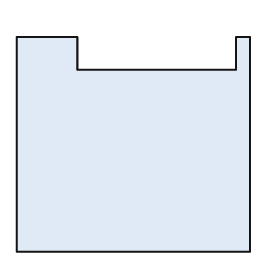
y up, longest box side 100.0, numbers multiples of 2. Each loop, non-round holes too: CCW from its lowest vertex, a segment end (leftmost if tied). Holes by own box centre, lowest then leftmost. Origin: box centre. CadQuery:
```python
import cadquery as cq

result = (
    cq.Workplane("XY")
    .moveTo(-50.0, -46.0)
    .lineTo(50.0, -46.0)
    .lineTo(50.0, 46.0)
    .lineTo(44.0, 46.0)
    .lineTo(44.0, 32.0)
    .lineTo(-24.0, 32.0)
    .lineTo(-24.0, 46.0)
    .lineTo(-50.0, 46.0)
    .close()
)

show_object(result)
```